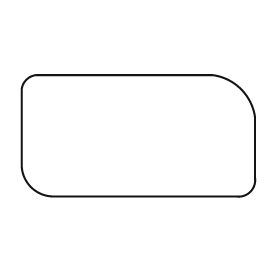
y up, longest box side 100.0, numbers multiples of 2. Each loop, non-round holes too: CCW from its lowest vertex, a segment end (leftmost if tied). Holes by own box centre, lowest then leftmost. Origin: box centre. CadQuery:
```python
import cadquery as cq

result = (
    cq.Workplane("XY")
    .moveTo(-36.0, -26.0)
    .lineTo(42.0, -26.0)
    .threePointArc((48.0, -24.0), (50.0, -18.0))
    .lineTo(50.0, 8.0)
    .threePointArc((44.0, 20.0), (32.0, 26.0))
    .lineTo(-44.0, 26.0)
    .threePointArc((-48.0, 24.0), (-50.0, 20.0))
    .lineTo(-50.0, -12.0)
    .threePointArc((-46.0, -22.0), (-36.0, -26.0))
    .close()
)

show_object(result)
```